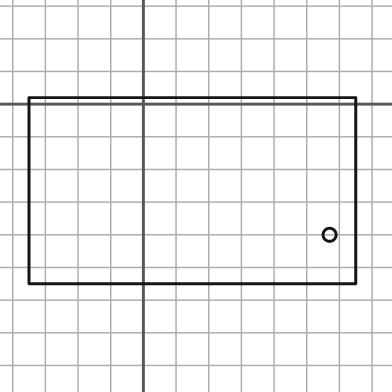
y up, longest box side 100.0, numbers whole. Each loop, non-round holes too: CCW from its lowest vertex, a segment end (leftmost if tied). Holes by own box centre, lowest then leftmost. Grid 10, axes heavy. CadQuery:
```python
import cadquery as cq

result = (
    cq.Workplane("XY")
    .moveTo(-35.0, -55.0)
    .lineTo(65.0, -55.0)
    .lineTo(65.0, 2.0)
    .lineTo(-35.0, 2.0)
    .close()
    .moveTo(57.0, -40.0)
    .circle(2.0)
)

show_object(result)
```